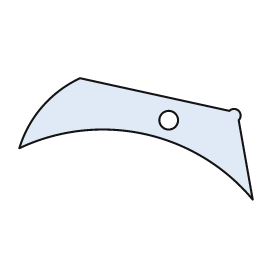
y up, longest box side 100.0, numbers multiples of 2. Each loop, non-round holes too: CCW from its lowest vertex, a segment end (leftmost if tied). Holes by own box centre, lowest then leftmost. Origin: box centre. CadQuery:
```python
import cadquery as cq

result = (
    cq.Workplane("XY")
    .moveTo(50.0, -26.0)
    .lineTo(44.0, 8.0)
    .threePointArc((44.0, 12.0), (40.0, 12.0))
    .lineTo(-24.0, 26.0)
    .threePointArc((-40.0, 14.0), (-50.0, -4.0))
    .threePointArc((4.0, 2.0), (50.0, -26.0))
    .close()
    .moveTo(14.0, 8.0)
    .circle(4.0)
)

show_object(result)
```